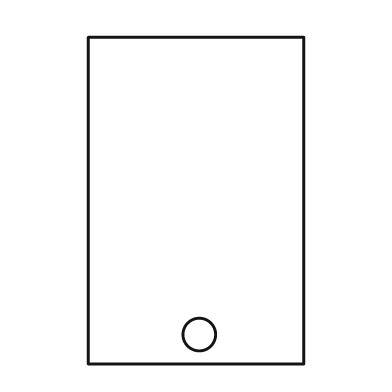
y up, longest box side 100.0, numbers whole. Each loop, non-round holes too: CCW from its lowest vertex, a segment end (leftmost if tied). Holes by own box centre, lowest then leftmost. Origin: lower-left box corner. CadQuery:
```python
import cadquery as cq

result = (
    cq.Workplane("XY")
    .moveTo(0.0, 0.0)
    .lineTo(66.0, 0.0)
    .lineTo(66.0, 100.0)
    .lineTo(0.0, 100.0)
    .close()
    .moveTo(34.0, 9.0)
    .circle(5.0)
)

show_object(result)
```